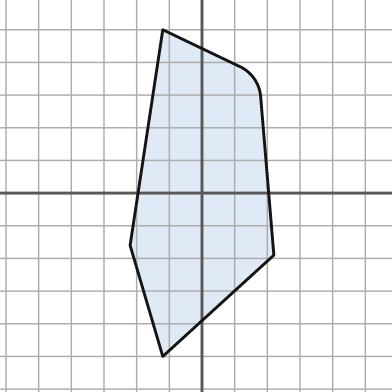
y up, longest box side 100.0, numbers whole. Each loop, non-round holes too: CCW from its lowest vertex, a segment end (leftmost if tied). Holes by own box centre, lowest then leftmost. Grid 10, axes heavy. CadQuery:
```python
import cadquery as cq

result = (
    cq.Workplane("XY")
    .moveTo(-12.0, -50.0)
    .lineTo(22.0, -19.0)
    .lineTo(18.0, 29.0)
    .threePointArc((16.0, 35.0), (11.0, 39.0))
    .lineTo(-12.0, 50.0)
    .lineTo(-22.0, -16.0)
    .close()
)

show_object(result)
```